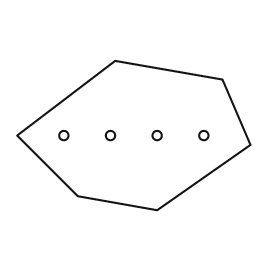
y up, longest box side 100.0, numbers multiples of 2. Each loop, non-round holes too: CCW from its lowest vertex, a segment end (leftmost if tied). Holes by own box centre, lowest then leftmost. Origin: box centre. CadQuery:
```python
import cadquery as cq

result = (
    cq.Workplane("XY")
    .moveTo(10.0, -32.0)
    .lineTo(50.0, -4.0)
    .lineTo(38.0, 24.0)
    .lineTo(-8.0, 32.0)
    .lineTo(-50.0, 0.0)
    .lineTo(-24.0, -26.0)
    .close()
    .moveTo(-30.0, 0.0)
    .circle(2.0)
    .moveTo(-10.0, 0.0)
    .circle(2.0)
    .moveTo(10.0, 0.0)
    .circle(2.0)
    .moveTo(30.0, 0.0)
    .circle(2.0)
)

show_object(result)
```